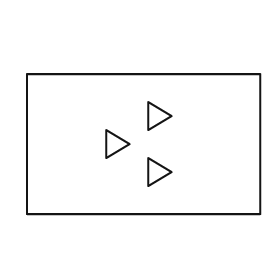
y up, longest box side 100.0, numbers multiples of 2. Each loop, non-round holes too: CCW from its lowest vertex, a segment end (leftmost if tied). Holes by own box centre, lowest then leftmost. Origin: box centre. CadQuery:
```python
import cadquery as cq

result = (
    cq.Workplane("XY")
    .moveTo(-50.0, -30.0)
    .lineTo(50.0, -30.0)
    .lineTo(50.0, 30.0)
    .lineTo(-50.0, 30.0)
    .close()
    .moveTo(2.0, -18.0)
    .lineTo(12.0, -12.0)
    .lineTo(2.0, -6.0)
    .close()
    .moveTo(-16.0, -6.0)
    .lineTo(-6.0, 0.0)
    .lineTo(-16.0, 6.0)
    .close()
    .moveTo(2.0, 6.0)
    .lineTo(12.0, 12.0)
    .lineTo(2.0, 18.0)
    .close()
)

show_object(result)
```